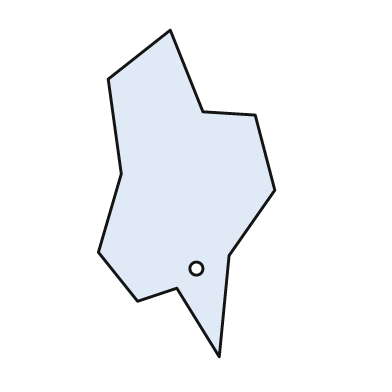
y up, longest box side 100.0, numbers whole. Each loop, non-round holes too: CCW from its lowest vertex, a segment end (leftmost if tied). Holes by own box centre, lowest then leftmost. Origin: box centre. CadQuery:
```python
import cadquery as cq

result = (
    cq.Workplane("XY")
    .moveTo(10.0, -50.0)
    .lineTo(13.0, -19.0)
    .lineTo(27.0, 1.0)
    .lineTo(21.0, 24.0)
    .lineTo(5.0, 25.0)
    .lineTo(-5.0, 50.0)
    .lineTo(-24.0, 35.0)
    .lineTo(-20.0, 6.0)
    .lineTo(-27.0, -18.0)
    .lineTo(-15.0, -33.0)
    .lineTo(-3.0, -29.0)
    .close()
    .moveTo(3.0, -23.0)
    .circle(2.0)
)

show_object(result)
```